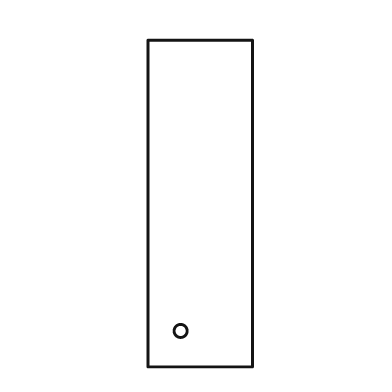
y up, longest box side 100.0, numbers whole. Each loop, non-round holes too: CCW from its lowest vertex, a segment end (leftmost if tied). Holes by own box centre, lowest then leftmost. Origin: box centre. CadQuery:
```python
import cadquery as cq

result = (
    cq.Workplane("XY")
    .moveTo(-16.0, -50.0)
    .lineTo(16.0, -50.0)
    .lineTo(16.0, 50.0)
    .lineTo(-16.0, 50.0)
    .close()
    .moveTo(-6.0, -39.0)
    .circle(2.0)
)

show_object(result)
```